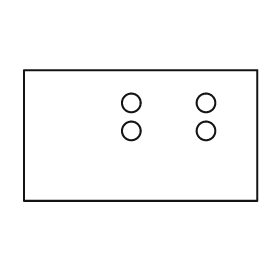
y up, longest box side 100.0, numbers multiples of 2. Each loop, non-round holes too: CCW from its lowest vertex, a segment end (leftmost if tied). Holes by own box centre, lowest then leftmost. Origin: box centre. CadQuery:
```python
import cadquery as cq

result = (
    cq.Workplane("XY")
    .moveTo(-50.0, -28.0)
    .lineTo(50.0, -28.0)
    .lineTo(50.0, 28.0)
    .lineTo(-50.0, 28.0)
    .close()
    .moveTo(-4.0, 2.0)
    .circle(4.0)
    .moveTo(28.0, 2.0)
    .circle(4.0)
    .moveTo(-4.0, 14.0)
    .circle(4.0)
    .moveTo(28.0, 14.0)
    .circle(4.0)
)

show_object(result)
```